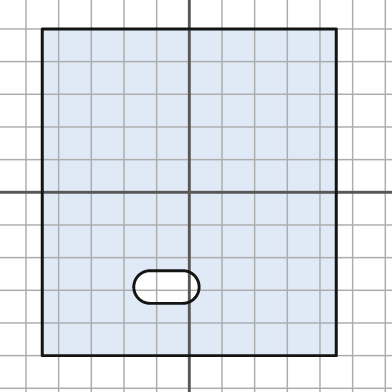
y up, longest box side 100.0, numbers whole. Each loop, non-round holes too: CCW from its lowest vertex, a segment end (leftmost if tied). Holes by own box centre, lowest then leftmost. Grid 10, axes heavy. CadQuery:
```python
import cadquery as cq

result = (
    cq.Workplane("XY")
    .moveTo(-45.0, -50.0)
    .lineTo(45.0, -50.0)
    .lineTo(45.0, 50.0)
    .lineTo(-45.0, 50.0)
    .close()
    .moveTo(-12.0, -34.0)
    .lineTo(-2.0, -34.0)
    .threePointArc((3.0, -29.0), (-2.0, -24.0))
    .lineTo(-12.0, -24.0)
    .threePointArc((-17.0, -29.0), (-12.0, -34.0))
    .close()
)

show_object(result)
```